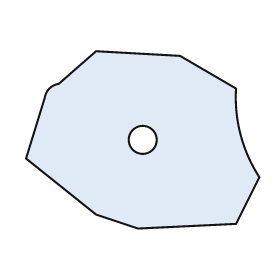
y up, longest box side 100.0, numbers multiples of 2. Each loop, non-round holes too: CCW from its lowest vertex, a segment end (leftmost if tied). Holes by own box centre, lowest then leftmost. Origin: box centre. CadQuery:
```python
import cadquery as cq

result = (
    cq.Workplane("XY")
    .moveTo(-2.0, -38.0)
    .lineTo(40.0, -36.0)
    .lineTo(50.0, -16.0)
    .threePointArc((42.0, 2.0), (40.0, 22.0))
    .lineTo(16.0, 36.0)
    .lineTo(-20.0, 38.0)
    .lineTo(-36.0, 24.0)
    .threePointArc((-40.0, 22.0), (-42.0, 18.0))
    .lineTo(-50.0, -8.0)
    .lineTo(-20.0, -32.0)
    .close()
    .moveTo(0.0, 0.0)
    .circle(6.0)
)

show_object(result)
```